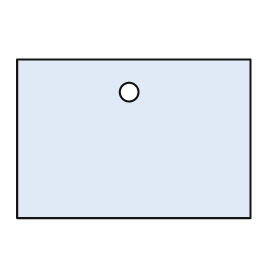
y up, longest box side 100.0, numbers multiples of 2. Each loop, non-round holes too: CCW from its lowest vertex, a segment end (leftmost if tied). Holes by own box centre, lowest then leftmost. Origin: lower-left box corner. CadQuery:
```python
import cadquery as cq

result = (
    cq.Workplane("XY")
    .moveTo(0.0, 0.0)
    .lineTo(100.0, 0.0)
    .lineTo(100.0, 68.0)
    .lineTo(0.0, 68.0)
    .close()
    .moveTo(48.0, 54.0)
    .circle(4.0)
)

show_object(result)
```